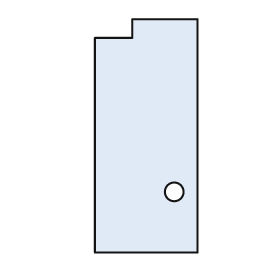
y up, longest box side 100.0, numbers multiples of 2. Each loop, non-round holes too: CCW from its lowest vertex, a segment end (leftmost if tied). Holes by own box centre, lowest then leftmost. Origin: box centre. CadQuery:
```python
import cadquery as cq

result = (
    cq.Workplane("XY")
    .moveTo(-22.0, -50.0)
    .lineTo(22.0, -50.0)
    .lineTo(22.0, 50.0)
    .lineTo(-6.0, 50.0)
    .lineTo(-6.0, 42.0)
    .lineTo(-22.0, 42.0)
    .close()
    .moveTo(12.0, -24.0)
    .circle(4.0)
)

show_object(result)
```